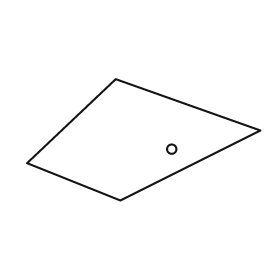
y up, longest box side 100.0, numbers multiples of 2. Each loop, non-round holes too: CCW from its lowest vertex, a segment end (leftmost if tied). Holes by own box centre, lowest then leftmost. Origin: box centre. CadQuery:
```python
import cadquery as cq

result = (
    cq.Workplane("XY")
    .moveTo(-10.0, -26.0)
    .lineTo(50.0, 4.0)
    .lineTo(-12.0, 26.0)
    .lineTo(-50.0, -10.0)
    .close()
    .moveTo(12.0, -4.0)
    .circle(2.0)
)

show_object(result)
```